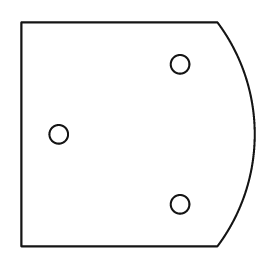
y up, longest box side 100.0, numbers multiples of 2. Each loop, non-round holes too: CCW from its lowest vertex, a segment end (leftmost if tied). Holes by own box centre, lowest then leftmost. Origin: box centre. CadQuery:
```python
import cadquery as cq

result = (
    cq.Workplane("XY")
    .moveTo(-50.0, -48.0)
    .lineTo(34.0, -48.0)
    .threePointArc((50.0, 0.0), (34.0, 48.0))
    .lineTo(-50.0, 48.0)
    .close()
    .moveTo(18.0, -30.0)
    .circle(4.0)
    .moveTo(-34.0, 0.0)
    .circle(4.0)
    .moveTo(18.0, 30.0)
    .circle(4.0)
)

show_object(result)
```